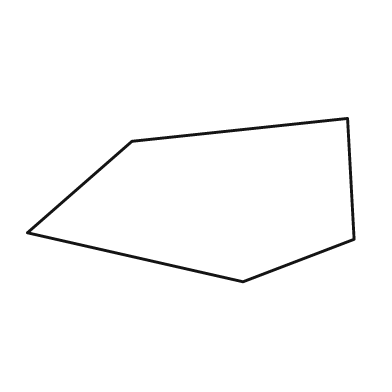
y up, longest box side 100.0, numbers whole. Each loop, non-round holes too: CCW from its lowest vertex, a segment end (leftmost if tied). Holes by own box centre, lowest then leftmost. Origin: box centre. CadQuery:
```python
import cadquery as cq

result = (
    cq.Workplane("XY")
    .moveTo(16.0, -25.0)
    .lineTo(50.0, -12.0)
    .lineTo(48.0, 25.0)
    .lineTo(-18.0, 18.0)
    .lineTo(-50.0, -10.0)
    .close()
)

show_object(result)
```